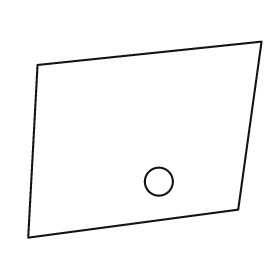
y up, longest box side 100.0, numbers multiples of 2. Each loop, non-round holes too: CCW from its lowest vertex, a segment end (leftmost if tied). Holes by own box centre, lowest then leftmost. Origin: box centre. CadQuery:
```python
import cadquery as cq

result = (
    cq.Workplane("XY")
    .moveTo(-50.0, -42.0)
    .lineTo(40.0, -30.0)
    .lineTo(50.0, 42.0)
    .lineTo(-46.0, 32.0)
    .close()
    .moveTo(6.0, -18.0)
    .circle(6.0)
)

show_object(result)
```